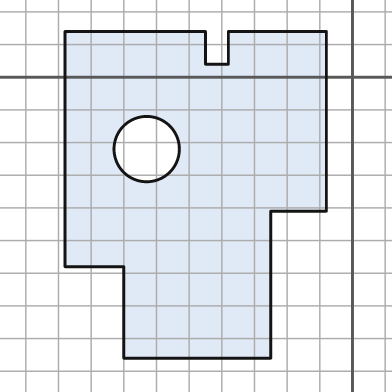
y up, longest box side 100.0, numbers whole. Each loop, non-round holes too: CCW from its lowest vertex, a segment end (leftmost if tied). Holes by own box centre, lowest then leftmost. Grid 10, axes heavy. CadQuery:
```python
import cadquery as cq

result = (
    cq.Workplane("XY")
    .moveTo(-70.0, -86.0)
    .lineTo(-25.0, -86.0)
    .lineTo(-25.0, -41.0)
    .lineTo(-8.0, -41.0)
    .lineTo(-8.0, 14.0)
    .lineTo(-38.0, 14.0)
    .lineTo(-38.0, 4.0)
    .lineTo(-45.0, 4.0)
    .lineTo(-45.0, 14.0)
    .lineTo(-88.0, 14.0)
    .lineTo(-88.0, -58.0)
    .lineTo(-70.0, -58.0)
    .close()
    .moveTo(-63.0, -22.0)
    .circle(10.0)
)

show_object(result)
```